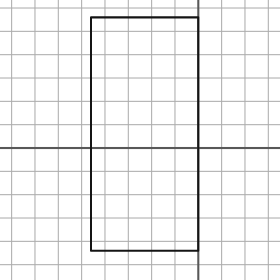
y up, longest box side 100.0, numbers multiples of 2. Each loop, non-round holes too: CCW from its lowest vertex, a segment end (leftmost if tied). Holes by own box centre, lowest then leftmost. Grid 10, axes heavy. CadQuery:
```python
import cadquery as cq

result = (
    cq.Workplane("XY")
    .moveTo(-46.0, -44.0)
    .lineTo(0.0, -44.0)
    .lineTo(0.0, 56.0)
    .lineTo(-46.0, 56.0)
    .close()
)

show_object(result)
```